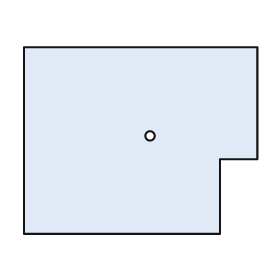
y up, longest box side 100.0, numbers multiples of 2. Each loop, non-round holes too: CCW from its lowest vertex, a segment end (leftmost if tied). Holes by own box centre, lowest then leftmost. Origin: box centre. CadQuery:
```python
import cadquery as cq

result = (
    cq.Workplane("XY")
    .moveTo(-50.0, -40.0)
    .lineTo(34.0, -40.0)
    .lineTo(34.0, -8.0)
    .lineTo(50.0, -8.0)
    .lineTo(50.0, 40.0)
    .lineTo(-50.0, 40.0)
    .close()
    .moveTo(4.0, 2.0)
    .circle(2.0)
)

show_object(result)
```